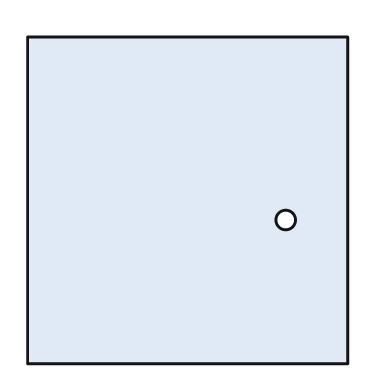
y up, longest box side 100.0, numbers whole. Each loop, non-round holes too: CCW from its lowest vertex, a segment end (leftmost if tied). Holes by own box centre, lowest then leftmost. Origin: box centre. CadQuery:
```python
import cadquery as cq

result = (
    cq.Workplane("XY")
    .moveTo(-49.0, -50.0)
    .lineTo(49.0, -50.0)
    .lineTo(49.0, 50.0)
    .lineTo(-49.0, 50.0)
    .close()
    .moveTo(30.0, -6.0)
    .circle(3.0)
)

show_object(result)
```